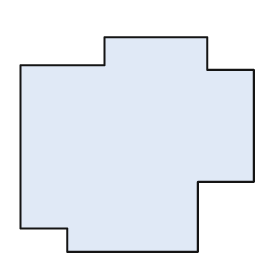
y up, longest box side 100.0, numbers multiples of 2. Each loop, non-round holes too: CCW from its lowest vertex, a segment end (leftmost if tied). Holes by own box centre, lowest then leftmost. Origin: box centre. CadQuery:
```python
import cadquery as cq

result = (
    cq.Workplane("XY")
    .moveTo(-30.0, -46.0)
    .lineTo(26.0, -46.0)
    .lineTo(26.0, -16.0)
    .lineTo(50.0, -16.0)
    .lineTo(50.0, 32.0)
    .lineTo(30.0, 32.0)
    .lineTo(30.0, 46.0)
    .lineTo(-14.0, 46.0)
    .lineTo(-14.0, 34.0)
    .lineTo(-50.0, 34.0)
    .lineTo(-50.0, -36.0)
    .lineTo(-30.0, -36.0)
    .close()
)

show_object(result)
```